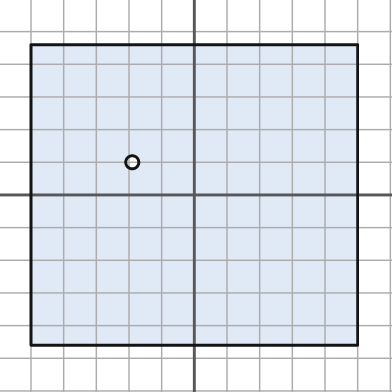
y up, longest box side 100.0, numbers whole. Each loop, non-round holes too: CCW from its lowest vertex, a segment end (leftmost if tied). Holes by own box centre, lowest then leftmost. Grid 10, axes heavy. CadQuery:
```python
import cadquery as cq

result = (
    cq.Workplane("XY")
    .moveTo(-50.0, -46.0)
    .lineTo(50.0, -46.0)
    .lineTo(50.0, 46.0)
    .lineTo(-50.0, 46.0)
    .close()
    .moveTo(-19.0, 10.0)
    .circle(2.0)
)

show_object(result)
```